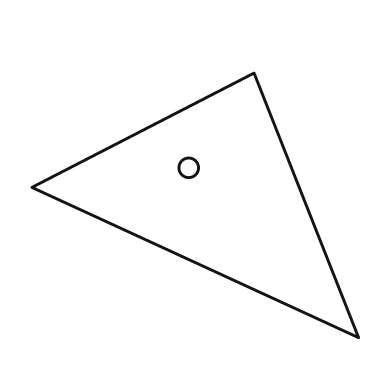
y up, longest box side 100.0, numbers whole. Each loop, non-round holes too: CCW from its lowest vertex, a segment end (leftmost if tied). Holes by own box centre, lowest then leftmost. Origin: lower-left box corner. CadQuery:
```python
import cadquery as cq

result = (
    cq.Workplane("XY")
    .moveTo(100.0, 0.0)
    .lineTo(68.0, 81.0)
    .lineTo(0.0, 46.0)
    .close()
    .moveTo(48.0, 52.0)
    .circle(3.0)
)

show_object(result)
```